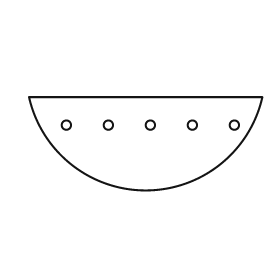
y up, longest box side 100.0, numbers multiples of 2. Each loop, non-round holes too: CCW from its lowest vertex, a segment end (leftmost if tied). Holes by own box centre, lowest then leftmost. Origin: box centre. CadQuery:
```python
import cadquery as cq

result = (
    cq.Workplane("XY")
    .moveTo(-50.0, 20.0)
    .threePointArc((0.0, -20.0), (50.0, 20.0))
    .close()
    .moveTo(-34.0, 8.0)
    .circle(2.0)
    .moveTo(-16.0, 8.0)
    .circle(2.0)
    .moveTo(2.0, 8.0)
    .circle(2.0)
    .moveTo(20.0, 8.0)
    .circle(2.0)
    .moveTo(38.0, 8.0)
    .circle(2.0)
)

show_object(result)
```